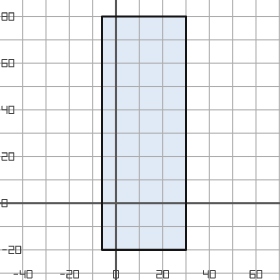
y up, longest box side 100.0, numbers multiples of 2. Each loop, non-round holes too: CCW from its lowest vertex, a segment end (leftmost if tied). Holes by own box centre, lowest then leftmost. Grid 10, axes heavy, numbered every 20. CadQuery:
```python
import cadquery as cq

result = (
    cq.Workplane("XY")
    .moveTo(-6.0, -20.0)
    .lineTo(30.0, -20.0)
    .lineTo(30.0, 80.0)
    .lineTo(-6.0, 80.0)
    .close()
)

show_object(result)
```